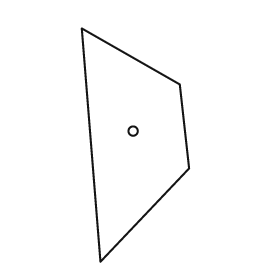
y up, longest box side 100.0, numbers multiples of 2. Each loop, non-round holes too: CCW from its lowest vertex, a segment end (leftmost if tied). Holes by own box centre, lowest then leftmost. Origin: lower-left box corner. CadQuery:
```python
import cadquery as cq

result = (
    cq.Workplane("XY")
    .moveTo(8.0, 0.0)
    .lineTo(46.0, 40.0)
    .lineTo(42.0, 76.0)
    .lineTo(0.0, 100.0)
    .close()
    .moveTo(22.0, 56.0)
    .circle(2.0)
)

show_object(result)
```